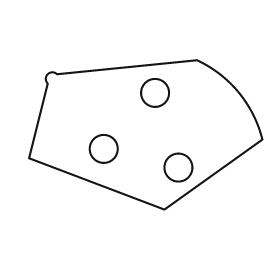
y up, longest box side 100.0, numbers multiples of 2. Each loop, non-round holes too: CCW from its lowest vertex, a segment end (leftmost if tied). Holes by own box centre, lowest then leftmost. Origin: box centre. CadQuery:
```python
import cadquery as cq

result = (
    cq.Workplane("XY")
    .moveTo(8.0, -32.0)
    .lineTo(50.0, -2.0)
    .threePointArc((40.0, 18.0), (22.0, 32.0))
    .lineTo(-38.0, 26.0)
    .threePointArc((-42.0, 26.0), (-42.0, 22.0))
    .lineTo(-50.0, -10.0)
    .close()
    .moveTo(14.0, -14.0)
    .circle(6.0)
    .moveTo(-18.0, -6.0)
    .circle(6.0)
    .moveTo(4.0, 18.0)
    .circle(6.0)
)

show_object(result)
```